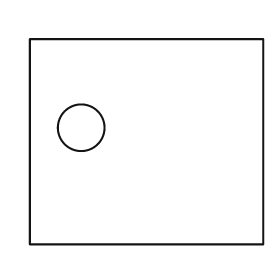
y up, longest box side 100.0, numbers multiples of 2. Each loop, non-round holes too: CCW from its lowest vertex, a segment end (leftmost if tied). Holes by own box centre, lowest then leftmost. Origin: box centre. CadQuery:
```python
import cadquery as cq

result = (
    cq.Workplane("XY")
    .moveTo(-50.0, -44.0)
    .lineTo(50.0, -44.0)
    .lineTo(50.0, 44.0)
    .lineTo(-50.0, 44.0)
    .close()
    .moveTo(-28.0, 6.0)
    .circle(10.0)
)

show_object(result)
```